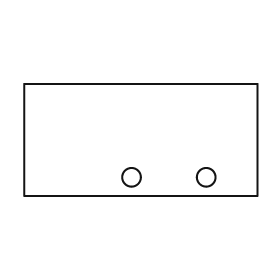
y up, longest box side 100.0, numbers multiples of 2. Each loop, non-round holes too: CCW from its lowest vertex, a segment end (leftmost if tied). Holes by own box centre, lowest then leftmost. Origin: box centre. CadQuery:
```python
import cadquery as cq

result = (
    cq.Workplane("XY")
    .moveTo(-50.0, -24.0)
    .lineTo(50.0, -24.0)
    .lineTo(50.0, 24.0)
    .lineTo(-50.0, 24.0)
    .close()
    .moveTo(-4.0, -16.0)
    .circle(4.0)
    .moveTo(28.0, -16.0)
    .circle(4.0)
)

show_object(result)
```